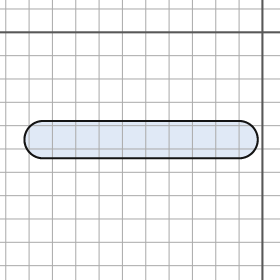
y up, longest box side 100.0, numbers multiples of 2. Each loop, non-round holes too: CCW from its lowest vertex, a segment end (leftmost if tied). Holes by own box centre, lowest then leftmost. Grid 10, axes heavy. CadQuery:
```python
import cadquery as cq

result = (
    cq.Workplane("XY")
    .moveTo(-94.0, -54.0)
    .lineTo(-10.0, -54.0)
    .threePointArc((-2.0, -46.0), (-10.0, -38.0))
    .lineTo(-94.0, -38.0)
    .threePointArc((-102.0, -46.0), (-94.0, -54.0))
    .close()
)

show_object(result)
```